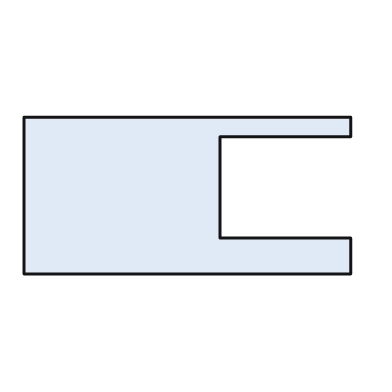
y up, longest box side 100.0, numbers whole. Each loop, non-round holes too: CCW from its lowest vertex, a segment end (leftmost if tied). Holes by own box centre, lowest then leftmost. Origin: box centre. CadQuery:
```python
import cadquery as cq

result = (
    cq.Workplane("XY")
    .moveTo(-50.0, -24.0)
    .lineTo(50.0, -24.0)
    .lineTo(50.0, -13.0)
    .lineTo(10.0, -13.0)
    .lineTo(10.0, 18.0)
    .lineTo(50.0, 18.0)
    .lineTo(50.0, 24.0)
    .lineTo(-50.0, 24.0)
    .close()
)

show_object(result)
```